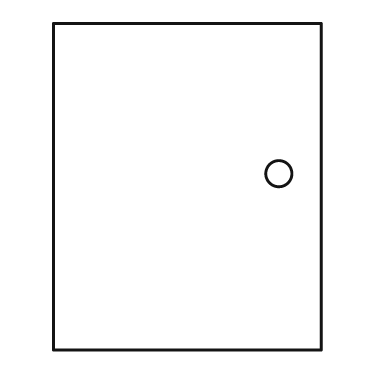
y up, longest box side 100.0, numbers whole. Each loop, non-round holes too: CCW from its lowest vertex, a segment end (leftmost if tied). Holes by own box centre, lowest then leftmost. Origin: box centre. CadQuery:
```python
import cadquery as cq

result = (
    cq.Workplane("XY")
    .moveTo(-41.0, -50.0)
    .lineTo(41.0, -50.0)
    .lineTo(41.0, 50.0)
    .lineTo(-41.0, 50.0)
    .close()
    .moveTo(28.0, 4.0)
    .circle(4.0)
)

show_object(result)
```